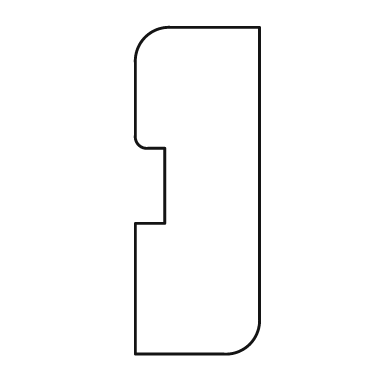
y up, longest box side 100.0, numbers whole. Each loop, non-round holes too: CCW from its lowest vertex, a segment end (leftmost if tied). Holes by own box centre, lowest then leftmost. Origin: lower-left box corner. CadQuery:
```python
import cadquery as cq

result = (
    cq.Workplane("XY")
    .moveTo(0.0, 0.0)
    .lineTo(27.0, 0.0)
    .threePointArc((35.0, 3.0), (38.0, 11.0))
    .lineTo(38.0, 100.0)
    .lineTo(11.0, 100.0)
    .threePointArc((3.0, 97.0), (0.0, 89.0))
    .lineTo(0.0, 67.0)
    .threePointArc((1.0, 64.0), (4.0, 63.0))
    .lineTo(9.0, 63.0)
    .lineTo(9.0, 40.0)
    .lineTo(0.0, 40.0)
    .close()
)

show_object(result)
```